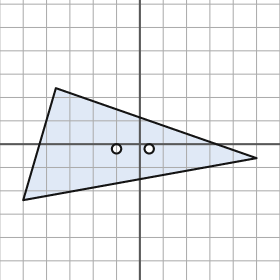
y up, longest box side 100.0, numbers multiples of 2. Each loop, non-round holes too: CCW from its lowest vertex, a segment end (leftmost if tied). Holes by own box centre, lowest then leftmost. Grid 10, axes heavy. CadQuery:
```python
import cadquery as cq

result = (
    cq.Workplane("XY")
    .moveTo(-50.0, -24.0)
    .lineTo(50.0, -6.0)
    .lineTo(-36.0, 24.0)
    .close()
    .moveTo(-10.0, -2.0)
    .circle(2.0)
    .moveTo(4.0, -2.0)
    .circle(2.0)
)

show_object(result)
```